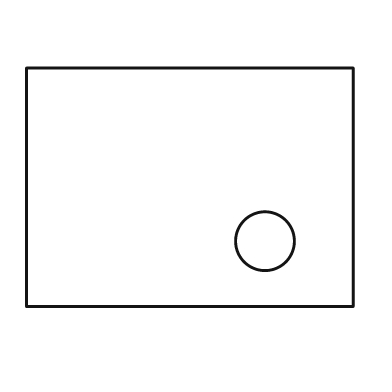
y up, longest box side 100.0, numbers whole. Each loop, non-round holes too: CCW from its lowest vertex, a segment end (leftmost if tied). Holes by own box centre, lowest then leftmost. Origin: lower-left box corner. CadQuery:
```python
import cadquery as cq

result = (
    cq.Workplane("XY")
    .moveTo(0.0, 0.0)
    .lineTo(100.0, 0.0)
    .lineTo(100.0, 73.0)
    .lineTo(0.0, 73.0)
    .close()
    .moveTo(73.0, 20.0)
    .circle(9.0)
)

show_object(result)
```